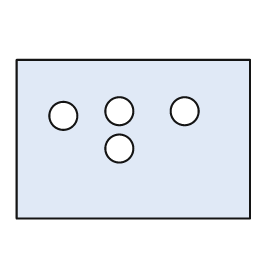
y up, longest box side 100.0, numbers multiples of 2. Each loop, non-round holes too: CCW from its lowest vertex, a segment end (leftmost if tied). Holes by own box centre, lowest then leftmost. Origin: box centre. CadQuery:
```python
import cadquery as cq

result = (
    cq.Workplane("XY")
    .moveTo(-50.0, -34.0)
    .lineTo(50.0, -34.0)
    .lineTo(50.0, 34.0)
    .lineTo(-50.0, 34.0)
    .close()
    .moveTo(-6.0, -4.0)
    .circle(6.0)
    .moveTo(-30.0, 10.0)
    .circle(6.0)
    .moveTo(-6.0, 12.0)
    .circle(6.0)
    .moveTo(22.0, 12.0)
    .circle(6.0)
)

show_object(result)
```